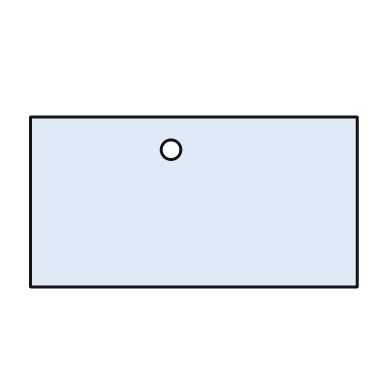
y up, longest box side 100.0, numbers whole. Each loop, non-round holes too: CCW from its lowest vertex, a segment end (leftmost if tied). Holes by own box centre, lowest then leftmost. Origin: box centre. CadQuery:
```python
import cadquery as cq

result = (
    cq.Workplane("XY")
    .moveTo(-50.0, -26.0)
    .lineTo(50.0, -26.0)
    .lineTo(50.0, 26.0)
    .lineTo(-50.0, 26.0)
    .close()
    .moveTo(-7.0, 16.0)
    .circle(3.0)
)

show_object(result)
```